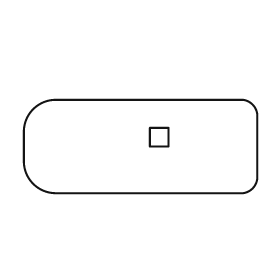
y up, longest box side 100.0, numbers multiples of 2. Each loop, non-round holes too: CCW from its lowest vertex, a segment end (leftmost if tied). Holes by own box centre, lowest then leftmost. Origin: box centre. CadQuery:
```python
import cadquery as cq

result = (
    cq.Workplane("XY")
    .moveTo(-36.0, -20.0)
    .lineTo(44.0, -20.0)
    .threePointArc((48.0, -18.0), (50.0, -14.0))
    .lineTo(50.0, 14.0)
    .threePointArc((48.0, 18.0), (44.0, 20.0))
    .lineTo(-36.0, 20.0)
    .threePointArc((-46.0, 16.0), (-50.0, 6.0))
    .lineTo(-50.0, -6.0)
    .threePointArc((-46.0, -16.0), (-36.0, -20.0))
    .close()
    .moveTo(4.0, 0.0)
    .lineTo(12.0, 0.0)
    .lineTo(12.0, 8.0)
    .lineTo(4.0, 8.0)
    .close()
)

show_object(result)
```